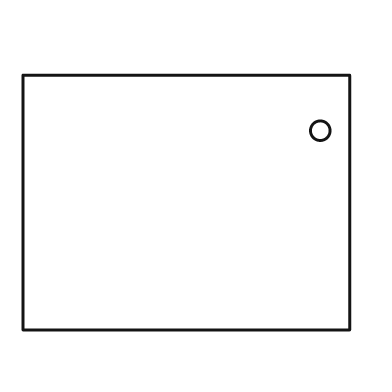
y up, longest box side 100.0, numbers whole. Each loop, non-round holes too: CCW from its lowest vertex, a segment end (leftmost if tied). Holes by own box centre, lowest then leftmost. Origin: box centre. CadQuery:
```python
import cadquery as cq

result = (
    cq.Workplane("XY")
    .moveTo(-50.0, -39.0)
    .lineTo(50.0, -39.0)
    .lineTo(50.0, 39.0)
    .lineTo(-50.0, 39.0)
    .close()
    .moveTo(41.0, 22.0)
    .circle(3.0)
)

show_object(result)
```